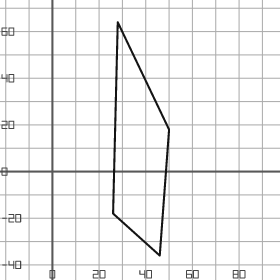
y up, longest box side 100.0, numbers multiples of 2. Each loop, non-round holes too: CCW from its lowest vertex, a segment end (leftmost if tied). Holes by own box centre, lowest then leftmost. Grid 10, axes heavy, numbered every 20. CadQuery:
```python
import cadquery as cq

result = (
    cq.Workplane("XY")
    .moveTo(46.0, -36.0)
    .lineTo(50.0, 18.0)
    .lineTo(28.0, 64.0)
    .lineTo(26.0, -18.0)
    .close()
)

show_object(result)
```